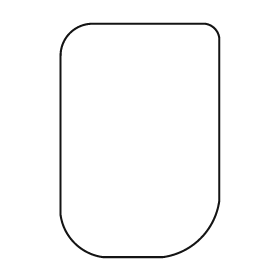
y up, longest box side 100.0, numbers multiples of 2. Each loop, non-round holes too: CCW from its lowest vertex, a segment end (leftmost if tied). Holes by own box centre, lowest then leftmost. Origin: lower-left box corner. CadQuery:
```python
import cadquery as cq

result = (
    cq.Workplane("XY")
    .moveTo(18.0, 0.0)
    .lineTo(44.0, 0.0)
    .threePointArc((60.0, 8.0), (68.0, 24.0))
    .lineTo(68.0, 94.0)
    .threePointArc((66.0, 98.0), (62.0, 100.0))
    .lineTo(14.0, 100.0)
    .threePointArc((4.0, 96.0), (0.0, 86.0))
    .lineTo(0.0, 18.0)
    .threePointArc((6.0, 6.0), (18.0, 0.0))
    .close()
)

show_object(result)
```